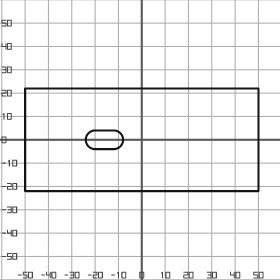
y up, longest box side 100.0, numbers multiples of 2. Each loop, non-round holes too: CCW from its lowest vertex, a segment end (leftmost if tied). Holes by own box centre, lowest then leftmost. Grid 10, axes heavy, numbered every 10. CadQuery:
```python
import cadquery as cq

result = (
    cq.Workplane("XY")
    .moveTo(-50.0, -22.0)
    .lineTo(50.0, -22.0)
    .lineTo(50.0, 22.0)
    .lineTo(-50.0, 22.0)
    .close()
    .moveTo(-20.0, -4.0)
    .lineTo(-12.0, -4.0)
    .threePointArc((-8.0, 0.0), (-12.0, 4.0))
    .lineTo(-20.0, 4.0)
    .threePointArc((-24.0, 0.0), (-20.0, -4.0))
    .close()
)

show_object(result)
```